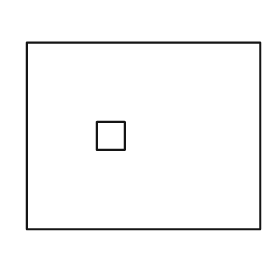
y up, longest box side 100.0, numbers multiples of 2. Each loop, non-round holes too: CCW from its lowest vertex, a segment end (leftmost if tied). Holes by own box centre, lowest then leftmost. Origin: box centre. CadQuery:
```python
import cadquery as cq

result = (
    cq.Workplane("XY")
    .moveTo(-50.0, -40.0)
    .lineTo(50.0, -40.0)
    .lineTo(50.0, 40.0)
    .lineTo(-50.0, 40.0)
    .close()
    .moveTo(-20.0, -6.0)
    .lineTo(-8.0, -6.0)
    .lineTo(-8.0, 6.0)
    .lineTo(-20.0, 6.0)
    .close()
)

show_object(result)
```